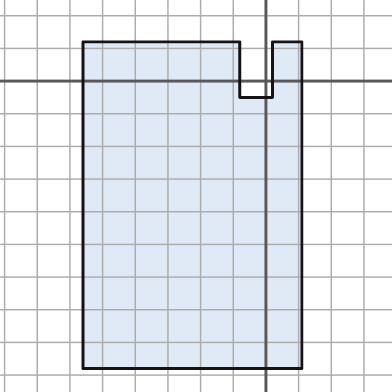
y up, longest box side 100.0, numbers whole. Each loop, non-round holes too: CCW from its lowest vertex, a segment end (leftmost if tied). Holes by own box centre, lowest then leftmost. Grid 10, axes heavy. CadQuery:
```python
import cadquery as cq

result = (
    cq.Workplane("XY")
    .moveTo(-56.0, -88.0)
    .lineTo(11.0, -88.0)
    .lineTo(11.0, 12.0)
    .lineTo(2.0, 12.0)
    .lineTo(2.0, -5.0)
    .lineTo(-8.0, -5.0)
    .lineTo(-8.0, 12.0)
    .lineTo(-56.0, 12.0)
    .close()
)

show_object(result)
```